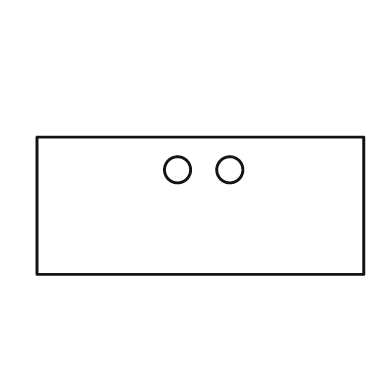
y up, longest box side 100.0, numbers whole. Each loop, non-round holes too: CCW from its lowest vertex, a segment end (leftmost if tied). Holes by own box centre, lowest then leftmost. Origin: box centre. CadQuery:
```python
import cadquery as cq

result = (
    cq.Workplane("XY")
    .moveTo(-50.0, -21.0)
    .lineTo(50.0, -21.0)
    .lineTo(50.0, 21.0)
    .lineTo(-50.0, 21.0)
    .close()
    .moveTo(-7.0, 11.0)
    .circle(4.0)
    .moveTo(9.0, 11.0)
    .circle(4.0)
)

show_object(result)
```